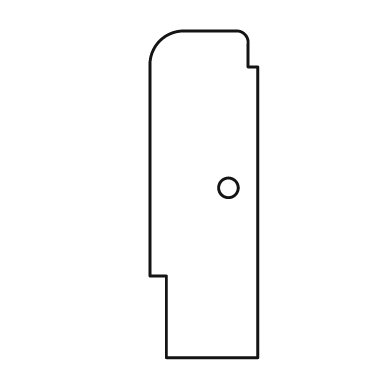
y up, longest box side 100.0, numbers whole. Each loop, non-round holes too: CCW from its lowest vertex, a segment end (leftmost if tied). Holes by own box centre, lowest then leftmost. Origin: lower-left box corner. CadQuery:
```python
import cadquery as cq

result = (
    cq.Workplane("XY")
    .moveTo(5.0, 0.0)
    .lineTo(33.0, 0.0)
    .lineTo(33.0, 89.0)
    .lineTo(30.0, 89.0)
    .lineTo(30.0, 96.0)
    .threePointArc((29.0, 99.0), (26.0, 100.0))
    .lineTo(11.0, 100.0)
    .threePointArc((3.0, 97.0), (0.0, 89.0))
    .lineTo(0.0, 25.0)
    .lineTo(5.0, 25.0)
    .close()
    .moveTo(24.0, 52.0)
    .circle(3.0)
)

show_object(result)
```